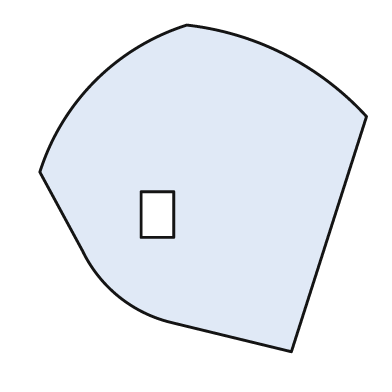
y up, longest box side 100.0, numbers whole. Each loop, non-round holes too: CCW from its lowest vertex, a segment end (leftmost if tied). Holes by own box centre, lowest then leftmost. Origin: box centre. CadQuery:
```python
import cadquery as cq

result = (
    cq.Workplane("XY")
    .moveTo(27.0, -50.0)
    .lineTo(50.0, 22.0)
    .threePointArc((25.0, 41.0), (-5.0, 50.0))
    .threePointArc((-33.0, 33.0), (-50.0, 5.0))
    .lineTo(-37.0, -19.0)
    .threePointArc((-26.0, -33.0), (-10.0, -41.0))
    .close()
    .moveTo(-19.0, -15.0)
    .lineTo(-9.0, -15.0)
    .lineTo(-9.0, -1.0)
    .lineTo(-19.0, -1.0)
    .close()
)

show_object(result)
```